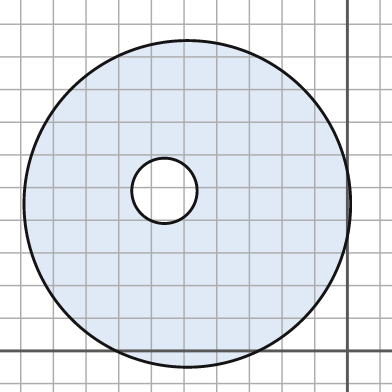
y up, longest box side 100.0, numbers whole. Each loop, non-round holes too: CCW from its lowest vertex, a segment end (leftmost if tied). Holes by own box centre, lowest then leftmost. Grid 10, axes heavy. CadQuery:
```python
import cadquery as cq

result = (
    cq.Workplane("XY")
    .moveTo(-49.0, 45.0)
    .circle(50.0)
    .moveTo(-56.0, 49.0)
    .circle(10.0)
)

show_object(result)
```